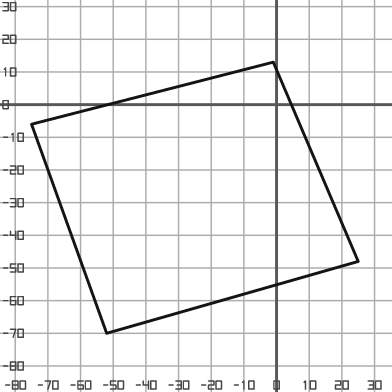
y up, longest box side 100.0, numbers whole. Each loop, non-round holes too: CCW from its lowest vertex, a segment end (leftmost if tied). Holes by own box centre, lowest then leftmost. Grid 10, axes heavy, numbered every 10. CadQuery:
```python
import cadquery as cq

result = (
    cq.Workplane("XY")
    .moveTo(-52.0, -70.0)
    .lineTo(25.0, -48.0)
    .lineTo(-1.0, 13.0)
    .lineTo(-75.0, -6.0)
    .close()
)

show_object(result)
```